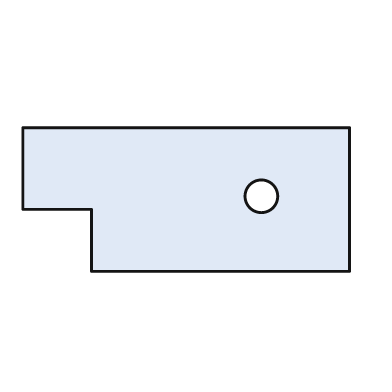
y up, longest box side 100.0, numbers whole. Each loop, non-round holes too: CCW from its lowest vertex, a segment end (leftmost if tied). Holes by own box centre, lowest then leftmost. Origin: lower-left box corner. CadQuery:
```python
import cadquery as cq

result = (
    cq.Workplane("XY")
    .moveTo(21.0, 0.0)
    .lineTo(100.0, 0.0)
    .lineTo(100.0, 44.0)
    .lineTo(0.0, 44.0)
    .lineTo(0.0, 19.0)
    .lineTo(21.0, 19.0)
    .close()
    .moveTo(73.0, 23.0)
    .circle(5.0)
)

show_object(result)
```